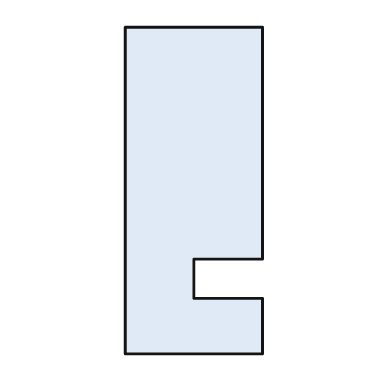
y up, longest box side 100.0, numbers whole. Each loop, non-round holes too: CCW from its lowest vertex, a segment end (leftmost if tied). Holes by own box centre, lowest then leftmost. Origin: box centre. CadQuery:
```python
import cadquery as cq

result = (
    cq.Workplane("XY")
    .moveTo(-21.0, -50.0)
    .lineTo(21.0, -50.0)
    .lineTo(21.0, -33.0)
    .lineTo(0.0, -33.0)
    .lineTo(0.0, -21.0)
    .lineTo(21.0, -21.0)
    .lineTo(21.0, 50.0)
    .lineTo(-21.0, 50.0)
    .close()
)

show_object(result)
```